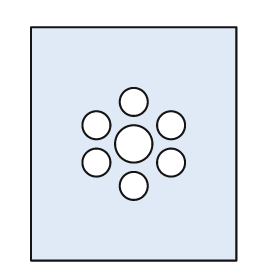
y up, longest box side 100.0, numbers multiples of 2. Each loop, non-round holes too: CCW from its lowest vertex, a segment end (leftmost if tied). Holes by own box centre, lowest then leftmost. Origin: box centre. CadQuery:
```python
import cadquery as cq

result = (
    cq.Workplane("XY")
    .moveTo(-44.0, -50.0)
    .lineTo(44.0, -50.0)
    .lineTo(44.0, 50.0)
    .lineTo(-44.0, 50.0)
    .close()
    .moveTo(0.0, -18.0)
    .circle(6.0)
    .moveTo(-16.0, -8.0)
    .circle(6.0)
    .moveTo(16.0, -8.0)
    .circle(6.0)
    .moveTo(0.0, 0.0)
    .circle(8.0)
    .moveTo(-16.0, 8.0)
    .circle(6.0)
    .moveTo(16.0, 8.0)
    .circle(6.0)
    .moveTo(0.0, 18.0)
    .circle(6.0)
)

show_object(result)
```